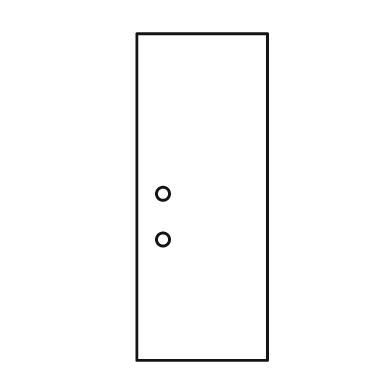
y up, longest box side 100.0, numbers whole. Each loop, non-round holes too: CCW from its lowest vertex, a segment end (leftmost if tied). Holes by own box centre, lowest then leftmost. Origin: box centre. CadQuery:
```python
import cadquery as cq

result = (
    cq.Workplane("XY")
    .moveTo(-20.0, -50.0)
    .lineTo(20.0, -50.0)
    .lineTo(20.0, 50.0)
    .lineTo(-20.0, 50.0)
    .close()
    .moveTo(-12.0, -13.0)
    .circle(2.0)
    .moveTo(-12.0, 1.0)
    .circle(2.0)
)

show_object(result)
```